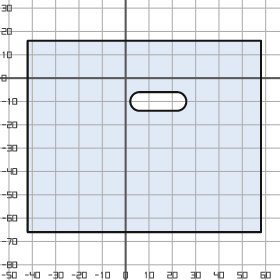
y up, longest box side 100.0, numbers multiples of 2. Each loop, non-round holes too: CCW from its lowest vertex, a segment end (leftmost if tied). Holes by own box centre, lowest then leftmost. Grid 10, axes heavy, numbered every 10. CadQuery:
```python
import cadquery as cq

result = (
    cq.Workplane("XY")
    .moveTo(-42.0, -66.0)
    .lineTo(58.0, -66.0)
    .lineTo(58.0, 16.0)
    .lineTo(-42.0, 16.0)
    .close()
    .moveTo(6.0, -14.0)
    .lineTo(22.0, -14.0)
    .threePointArc((26.0, -10.0), (22.0, -6.0))
    .lineTo(6.0, -6.0)
    .threePointArc((2.0, -10.0), (6.0, -14.0))
    .close()
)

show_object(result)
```